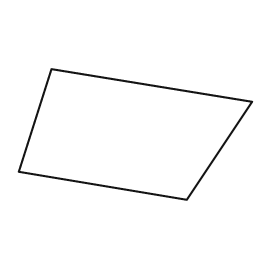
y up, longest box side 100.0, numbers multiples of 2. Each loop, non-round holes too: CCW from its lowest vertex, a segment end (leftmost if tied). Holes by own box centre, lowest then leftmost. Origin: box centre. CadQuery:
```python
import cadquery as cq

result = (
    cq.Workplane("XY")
    .moveTo(22.0, -28.0)
    .lineTo(50.0, 14.0)
    .lineTo(-36.0, 28.0)
    .lineTo(-50.0, -16.0)
    .close()
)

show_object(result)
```